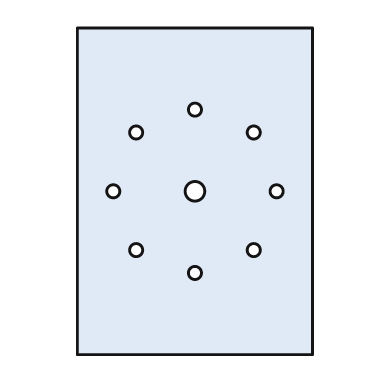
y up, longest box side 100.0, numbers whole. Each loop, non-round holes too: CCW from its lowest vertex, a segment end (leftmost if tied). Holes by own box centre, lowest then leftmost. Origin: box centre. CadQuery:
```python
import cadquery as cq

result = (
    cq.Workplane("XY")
    .moveTo(-36.0, -50.0)
    .lineTo(36.0, -50.0)
    .lineTo(36.0, 50.0)
    .lineTo(-36.0, 50.0)
    .close()
    .moveTo(0.0, -25.0)
    .circle(2.0)
    .moveTo(-18.0, -18.0)
    .circle(2.0)
    .moveTo(18.0, -18.0)
    .circle(2.0)
    .moveTo(-25.0, 0.0)
    .circle(2.0)
    .moveTo(0.0, 0.0)
    .circle(3.0)
    .moveTo(25.0, 0.0)
    .circle(2.0)
    .moveTo(-18.0, 18.0)
    .circle(2.0)
    .moveTo(18.0, 18.0)
    .circle(2.0)
    .moveTo(0.0, 25.0)
    .circle(2.0)
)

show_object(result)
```